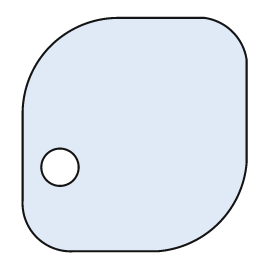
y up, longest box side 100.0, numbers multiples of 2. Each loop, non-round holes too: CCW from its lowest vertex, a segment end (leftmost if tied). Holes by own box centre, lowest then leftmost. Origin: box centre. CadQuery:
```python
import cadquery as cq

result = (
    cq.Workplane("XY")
    .moveTo(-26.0, -50.0)
    .lineTo(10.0, -50.0)
    .threePointArc((36.0, -38.0), (48.0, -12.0))
    .lineTo(48.0, 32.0)
    .threePointArc((42.0, 44.0), (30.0, 50.0))
    .lineTo(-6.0, 50.0)
    .threePointArc((-36.0, 38.0), (-48.0, 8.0))
    .lineTo(-48.0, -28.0)
    .threePointArc((-42.0, -44.0), (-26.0, -50.0))
    .close()
    .moveTo(-32.0, -14.0)
    .circle(8.0)
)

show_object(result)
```